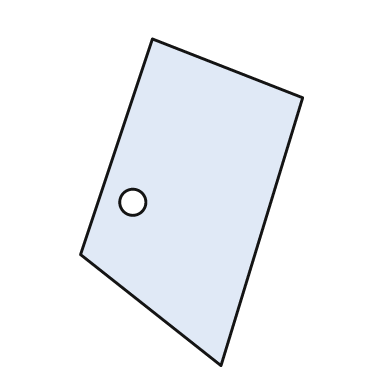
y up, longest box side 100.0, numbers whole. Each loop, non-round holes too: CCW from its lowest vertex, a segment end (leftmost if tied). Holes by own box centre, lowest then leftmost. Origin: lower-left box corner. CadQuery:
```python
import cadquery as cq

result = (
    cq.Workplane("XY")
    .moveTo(43.0, 0.0)
    .lineTo(68.0, 82.0)
    .lineTo(22.0, 100.0)
    .lineTo(0.0, 34.0)
    .close()
    .moveTo(16.0, 50.0)
    .circle(4.0)
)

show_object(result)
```